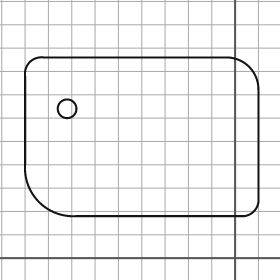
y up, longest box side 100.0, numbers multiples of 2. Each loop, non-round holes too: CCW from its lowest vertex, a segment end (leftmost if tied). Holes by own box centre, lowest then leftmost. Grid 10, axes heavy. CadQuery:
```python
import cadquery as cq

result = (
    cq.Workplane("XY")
    .moveTo(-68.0, 18.0)
    .lineTo(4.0, 18.0)
    .threePointArc((8.0, 20.0), (10.0, 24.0))
    .lineTo(10.0, 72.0)
    .threePointArc((6.0, 82.0), (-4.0, 86.0))
    .lineTo(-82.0, 86.0)
    .threePointArc((-88.0, 84.0), (-90.0, 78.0))
    .lineTo(-90.0, 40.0)
    .threePointArc((-84.0, 24.0), (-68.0, 18.0))
    .close()
    .moveTo(-72.0, 64.0)
    .circle(4.0)
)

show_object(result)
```